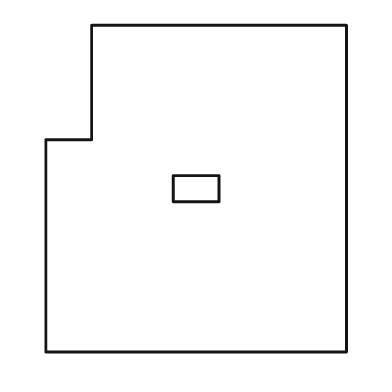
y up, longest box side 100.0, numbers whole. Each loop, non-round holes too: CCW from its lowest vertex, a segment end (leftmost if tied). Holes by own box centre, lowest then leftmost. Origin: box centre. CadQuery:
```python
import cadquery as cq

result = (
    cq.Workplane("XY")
    .moveTo(-46.0, -50.0)
    .lineTo(46.0, -50.0)
    .lineTo(46.0, 50.0)
    .lineTo(-32.0, 50.0)
    .lineTo(-32.0, 15.0)
    .lineTo(-46.0, 15.0)
    .close()
    .moveTo(-7.0, -4.0)
    .lineTo(7.0, -4.0)
    .lineTo(7.0, 4.0)
    .lineTo(-7.0, 4.0)
    .close()
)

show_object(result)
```